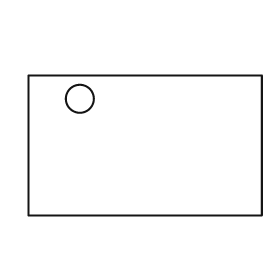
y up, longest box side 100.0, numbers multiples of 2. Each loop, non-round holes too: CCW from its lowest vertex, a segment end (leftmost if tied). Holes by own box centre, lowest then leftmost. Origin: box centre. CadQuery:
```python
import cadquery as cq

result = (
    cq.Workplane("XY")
    .moveTo(-50.0, -30.0)
    .lineTo(50.0, -30.0)
    .lineTo(50.0, 30.0)
    .lineTo(-50.0, 30.0)
    .close()
    .moveTo(-28.0, 20.0)
    .circle(6.0)
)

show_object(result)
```